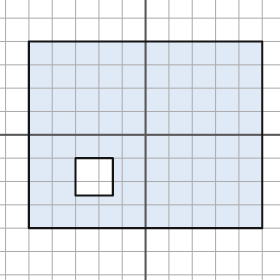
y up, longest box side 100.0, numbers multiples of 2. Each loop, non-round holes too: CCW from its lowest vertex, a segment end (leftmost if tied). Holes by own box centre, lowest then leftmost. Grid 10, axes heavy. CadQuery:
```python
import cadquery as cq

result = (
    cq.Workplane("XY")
    .moveTo(-50.0, -40.0)
    .lineTo(50.0, -40.0)
    .lineTo(50.0, 40.0)
    .lineTo(-50.0, 40.0)
    .close()
    .moveTo(-30.0, -26.0)
    .lineTo(-14.0, -26.0)
    .lineTo(-14.0, -10.0)
    .lineTo(-30.0, -10.0)
    .close()
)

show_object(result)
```